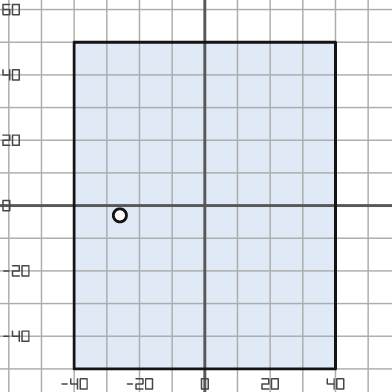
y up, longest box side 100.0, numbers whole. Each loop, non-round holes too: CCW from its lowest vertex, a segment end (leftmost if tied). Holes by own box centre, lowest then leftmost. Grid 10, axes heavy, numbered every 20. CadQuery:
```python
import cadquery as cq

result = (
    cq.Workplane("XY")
    .moveTo(-40.0, -50.0)
    .lineTo(40.0, -50.0)
    .lineTo(40.0, 50.0)
    .lineTo(-40.0, 50.0)
    .close()
    .moveTo(-26.0, -3.0)
    .circle(2.0)
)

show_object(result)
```